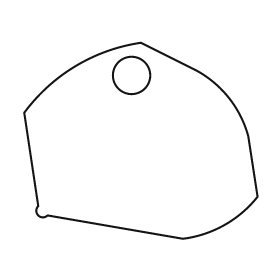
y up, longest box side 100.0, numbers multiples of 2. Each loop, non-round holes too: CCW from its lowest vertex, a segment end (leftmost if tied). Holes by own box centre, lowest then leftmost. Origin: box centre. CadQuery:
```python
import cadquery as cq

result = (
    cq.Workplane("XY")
    .moveTo(18.0, -42.0)
    .threePointArc((36.0, -36.0), (50.0, -24.0))
    .lineTo(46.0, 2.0)
    .threePointArc((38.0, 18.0), (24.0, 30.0))
    .lineTo(0.0, 42.0)
    .threePointArc((-28.0, 32.0), (-50.0, 12.0))
    .lineTo(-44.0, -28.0)
    .threePointArc((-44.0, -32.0), (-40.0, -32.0))
    .close()
    .moveTo(-4.0, 28.0)
    .circle(8.0)
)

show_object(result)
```